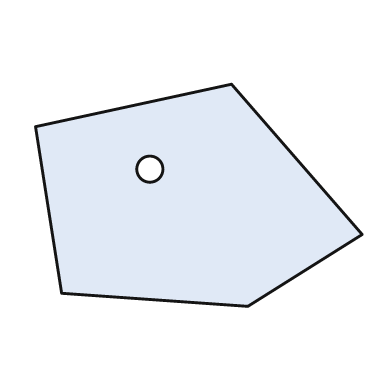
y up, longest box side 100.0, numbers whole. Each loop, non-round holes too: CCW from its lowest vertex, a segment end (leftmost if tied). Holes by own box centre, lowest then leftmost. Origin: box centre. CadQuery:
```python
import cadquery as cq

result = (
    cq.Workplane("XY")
    .moveTo(15.0, -34.0)
    .lineTo(50.0, -12.0)
    .lineTo(10.0, 34.0)
    .lineTo(-50.0, 21.0)
    .lineTo(-42.0, -30.0)
    .close()
    .moveTo(-15.0, 8.0)
    .circle(4.0)
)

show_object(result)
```